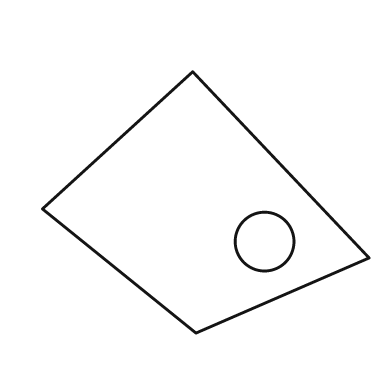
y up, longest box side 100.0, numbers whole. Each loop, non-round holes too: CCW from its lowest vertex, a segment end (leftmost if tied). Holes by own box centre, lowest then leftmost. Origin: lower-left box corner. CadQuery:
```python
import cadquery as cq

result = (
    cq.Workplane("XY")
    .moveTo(47.0, 0.0)
    .lineTo(100.0, 23.0)
    .lineTo(46.0, 80.0)
    .lineTo(0.0, 38.0)
    .close()
    .moveTo(68.0, 28.0)
    .circle(9.0)
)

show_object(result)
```